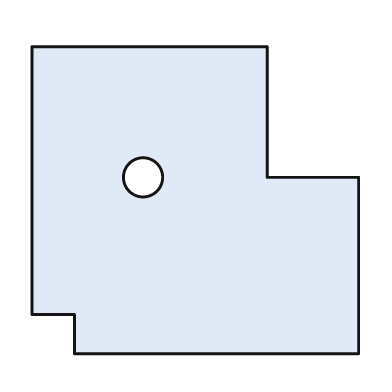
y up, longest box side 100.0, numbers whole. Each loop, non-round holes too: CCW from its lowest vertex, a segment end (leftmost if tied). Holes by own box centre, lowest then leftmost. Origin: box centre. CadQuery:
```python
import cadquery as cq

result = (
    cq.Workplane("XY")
    .moveTo(-37.0, -47.0)
    .lineTo(50.0, -47.0)
    .lineTo(50.0, 7.0)
    .lineTo(22.0, 7.0)
    .lineTo(22.0, 47.0)
    .lineTo(-50.0, 47.0)
    .lineTo(-50.0, -35.0)
    .lineTo(-37.0, -35.0)
    .close()
    .moveTo(-16.0, 7.0)
    .circle(6.0)
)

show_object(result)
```